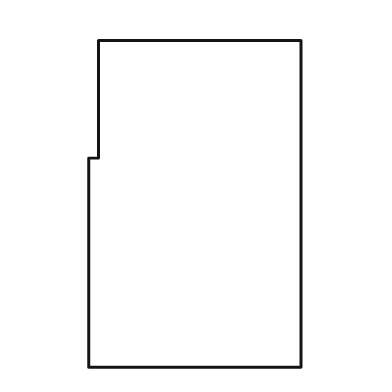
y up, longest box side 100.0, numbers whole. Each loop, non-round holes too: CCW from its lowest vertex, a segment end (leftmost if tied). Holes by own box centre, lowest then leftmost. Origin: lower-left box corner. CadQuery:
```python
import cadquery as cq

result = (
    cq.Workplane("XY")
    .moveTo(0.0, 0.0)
    .lineTo(65.0, 0.0)
    .lineTo(65.0, 100.0)
    .lineTo(3.0, 100.0)
    .lineTo(3.0, 64.0)
    .lineTo(0.0, 64.0)
    .close()
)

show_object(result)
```